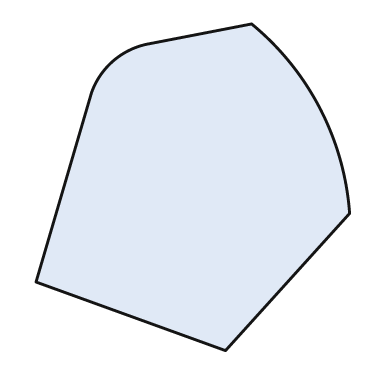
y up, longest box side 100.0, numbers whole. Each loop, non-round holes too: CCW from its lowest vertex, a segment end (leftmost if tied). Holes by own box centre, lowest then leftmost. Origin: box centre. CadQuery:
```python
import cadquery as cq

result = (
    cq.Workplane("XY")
    .moveTo(10.0, -50.0)
    .lineTo(48.0, -8.0)
    .threePointArc((39.0, 24.0), (18.0, 50.0))
    .lineTo(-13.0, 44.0)
    .threePointArc((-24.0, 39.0), (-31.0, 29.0))
    .lineTo(-48.0, -29.0)
    .close()
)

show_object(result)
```